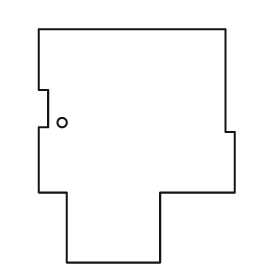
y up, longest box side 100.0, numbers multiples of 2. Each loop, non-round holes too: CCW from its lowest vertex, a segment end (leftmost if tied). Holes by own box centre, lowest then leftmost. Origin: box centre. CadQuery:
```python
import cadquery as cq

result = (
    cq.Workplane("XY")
    .moveTo(-30.0, -50.0)
    .lineTo(10.0, -50.0)
    .lineTo(10.0, -20.0)
    .lineTo(42.0, -20.0)
    .lineTo(42.0, 6.0)
    .lineTo(38.0, 6.0)
    .lineTo(38.0, 50.0)
    .lineTo(-42.0, 50.0)
    .lineTo(-42.0, 24.0)
    .lineTo(-38.0, 24.0)
    .lineTo(-38.0, 8.0)
    .lineTo(-42.0, 8.0)
    .lineTo(-42.0, -20.0)
    .lineTo(-30.0, -20.0)
    .close()
    .moveTo(-32.0, 10.0)
    .circle(2.0)
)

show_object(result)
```